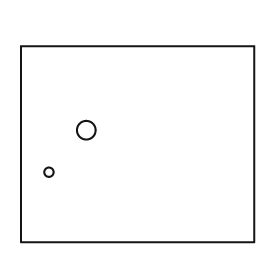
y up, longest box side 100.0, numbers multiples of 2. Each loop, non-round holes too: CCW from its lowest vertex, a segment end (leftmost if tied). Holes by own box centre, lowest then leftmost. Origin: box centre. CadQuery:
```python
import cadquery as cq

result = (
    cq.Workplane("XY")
    .moveTo(-50.0, -42.0)
    .lineTo(50.0, -42.0)
    .lineTo(50.0, 42.0)
    .lineTo(-50.0, 42.0)
    .close()
    .moveTo(-38.0, -12.0)
    .circle(2.0)
    .moveTo(-22.0, 6.0)
    .circle(4.0)
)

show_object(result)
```